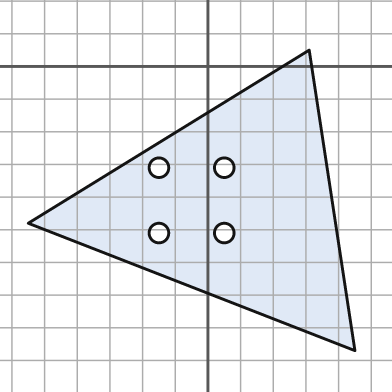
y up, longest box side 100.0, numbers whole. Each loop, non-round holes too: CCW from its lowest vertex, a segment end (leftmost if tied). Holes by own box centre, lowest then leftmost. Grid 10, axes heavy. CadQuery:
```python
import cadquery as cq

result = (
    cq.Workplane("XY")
    .moveTo(45.0, -87.0)
    .lineTo(31.0, 5.0)
    .lineTo(-55.0, -48.0)
    .close()
    .moveTo(-15.0, -51.0)
    .circle(3.0)
    .moveTo(5.0, -51.0)
    .circle(3.0)
    .moveTo(-15.0, -31.0)
    .circle(3.0)
    .moveTo(5.0, -31.0)
    .circle(3.0)
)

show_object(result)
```